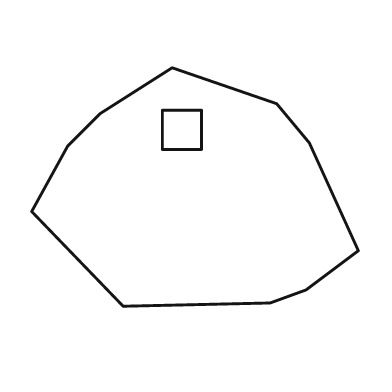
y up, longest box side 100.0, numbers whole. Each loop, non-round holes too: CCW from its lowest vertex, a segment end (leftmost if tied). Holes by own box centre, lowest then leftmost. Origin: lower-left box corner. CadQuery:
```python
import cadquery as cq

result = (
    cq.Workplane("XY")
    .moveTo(28.0, 0.0)
    .lineTo(73.0, 1.0)
    .lineTo(84.0, 5.0)
    .lineTo(100.0, 17.0)
    .lineTo(85.0, 50.0)
    .lineTo(75.0, 62.0)
    .lineTo(43.0, 73.0)
    .lineTo(21.0, 59.0)
    .lineTo(11.0, 49.0)
    .lineTo(0.0, 29.0)
    .close()
    .moveTo(40.0, 48.0)
    .lineTo(52.0, 48.0)
    .lineTo(52.0, 60.0)
    .lineTo(40.0, 60.0)
    .close()
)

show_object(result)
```